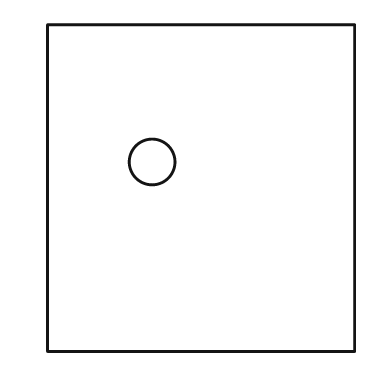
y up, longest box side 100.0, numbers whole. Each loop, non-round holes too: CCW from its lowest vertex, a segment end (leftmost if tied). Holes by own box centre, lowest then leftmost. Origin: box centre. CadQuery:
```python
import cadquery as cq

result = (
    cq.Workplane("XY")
    .moveTo(-47.0, -50.0)
    .lineTo(47.0, -50.0)
    .lineTo(47.0, 50.0)
    .lineTo(-47.0, 50.0)
    .close()
    .moveTo(-15.0, 8.0)
    .circle(7.0)
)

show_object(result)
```